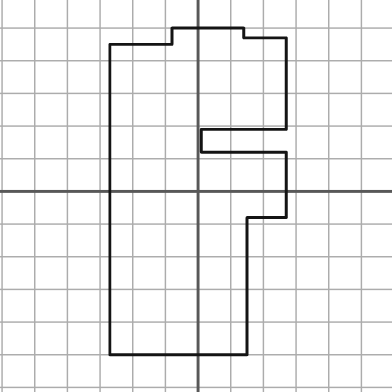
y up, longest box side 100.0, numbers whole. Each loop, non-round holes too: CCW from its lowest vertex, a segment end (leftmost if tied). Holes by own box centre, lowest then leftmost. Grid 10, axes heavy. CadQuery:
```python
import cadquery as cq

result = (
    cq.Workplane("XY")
    .moveTo(-27.0, -50.0)
    .lineTo(15.0, -50.0)
    .lineTo(15.0, -8.0)
    .lineTo(27.0, -8.0)
    .lineTo(27.0, 12.0)
    .lineTo(1.0, 12.0)
    .lineTo(1.0, 19.0)
    .lineTo(27.0, 19.0)
    .lineTo(27.0, 47.0)
    .lineTo(14.0, 47.0)
    .lineTo(14.0, 50.0)
    .lineTo(-8.0, 50.0)
    .lineTo(-8.0, 45.0)
    .lineTo(-27.0, 45.0)
    .close()
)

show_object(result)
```